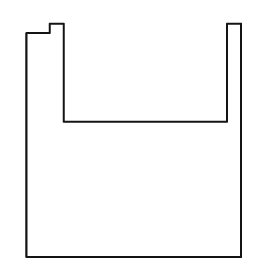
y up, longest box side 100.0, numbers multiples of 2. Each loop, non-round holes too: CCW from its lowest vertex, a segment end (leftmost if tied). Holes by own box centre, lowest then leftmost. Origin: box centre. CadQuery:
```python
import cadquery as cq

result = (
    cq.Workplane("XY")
    .moveTo(-46.0, -50.0)
    .lineTo(46.0, -50.0)
    .lineTo(46.0, 50.0)
    .lineTo(40.0, 50.0)
    .lineTo(40.0, 8.0)
    .lineTo(-30.0, 8.0)
    .lineTo(-30.0, 50.0)
    .lineTo(-36.0, 50.0)
    .lineTo(-36.0, 46.0)
    .lineTo(-46.0, 46.0)
    .close()
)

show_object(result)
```